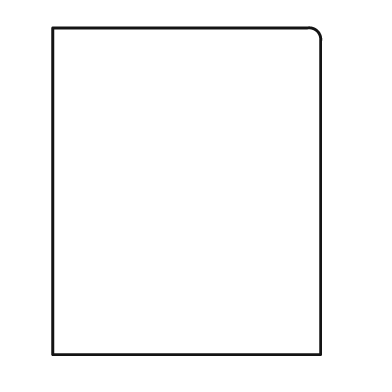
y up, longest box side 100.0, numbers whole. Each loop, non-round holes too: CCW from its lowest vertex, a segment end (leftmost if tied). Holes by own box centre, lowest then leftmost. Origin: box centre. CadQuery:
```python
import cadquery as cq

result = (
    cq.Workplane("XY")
    .moveTo(-41.0, -50.0)
    .lineTo(41.0, -50.0)
    .lineTo(41.0, 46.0)
    .threePointArc((40.0, 49.0), (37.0, 50.0))
    .lineTo(-41.0, 50.0)
    .close()
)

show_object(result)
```